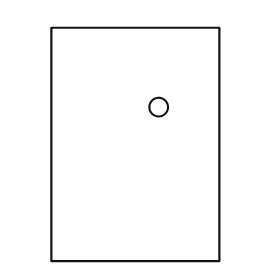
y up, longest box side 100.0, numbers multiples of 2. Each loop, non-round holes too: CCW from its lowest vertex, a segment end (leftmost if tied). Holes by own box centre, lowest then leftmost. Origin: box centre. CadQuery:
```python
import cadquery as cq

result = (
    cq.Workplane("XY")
    .moveTo(-36.0, -50.0)
    .lineTo(36.0, -50.0)
    .lineTo(36.0, 50.0)
    .lineTo(-36.0, 50.0)
    .close()
    .moveTo(10.0, 16.0)
    .circle(4.0)
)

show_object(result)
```